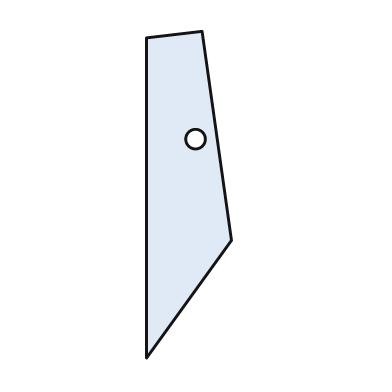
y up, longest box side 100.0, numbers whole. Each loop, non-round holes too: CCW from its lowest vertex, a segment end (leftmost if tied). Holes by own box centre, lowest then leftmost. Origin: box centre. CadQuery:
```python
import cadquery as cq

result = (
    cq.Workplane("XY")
    .moveTo(-13.0, -50.0)
    .lineTo(13.0, -14.0)
    .lineTo(4.0, 50.0)
    .lineTo(-13.0, 48.0)
    .close()
    .moveTo(2.0, 17.0)
    .circle(3.0)
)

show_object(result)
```